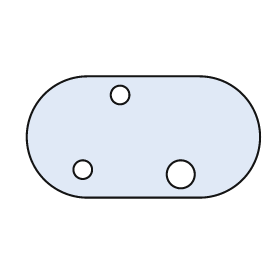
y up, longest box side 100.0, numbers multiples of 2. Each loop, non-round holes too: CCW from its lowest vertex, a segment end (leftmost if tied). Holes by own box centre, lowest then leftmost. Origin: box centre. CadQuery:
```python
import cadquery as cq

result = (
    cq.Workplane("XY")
    .moveTo(-24.0, -26.0)
    .lineTo(24.0, -26.0)
    .threePointArc((50.0, 0.0), (24.0, 26.0))
    .lineTo(-24.0, 26.0)
    .threePointArc((-50.0, 0.0), (-24.0, -26.0))
    .close()
    .moveTo(16.0, -16.0)
    .circle(6.0)
    .moveTo(-26.0, -14.0)
    .circle(4.0)
    .moveTo(-10.0, 18.0)
    .circle(4.0)
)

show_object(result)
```